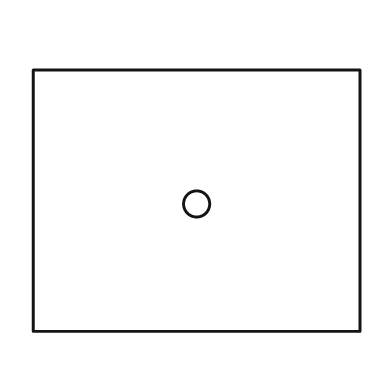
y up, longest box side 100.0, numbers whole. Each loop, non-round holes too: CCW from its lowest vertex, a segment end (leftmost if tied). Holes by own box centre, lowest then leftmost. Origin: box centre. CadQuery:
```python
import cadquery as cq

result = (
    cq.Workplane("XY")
    .moveTo(-50.0, -40.0)
    .lineTo(50.0, -40.0)
    .lineTo(50.0, 40.0)
    .lineTo(-50.0, 40.0)
    .close()
    .moveTo(0.0, -1.0)
    .circle(4.0)
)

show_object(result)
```